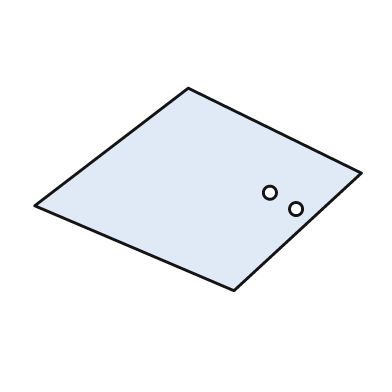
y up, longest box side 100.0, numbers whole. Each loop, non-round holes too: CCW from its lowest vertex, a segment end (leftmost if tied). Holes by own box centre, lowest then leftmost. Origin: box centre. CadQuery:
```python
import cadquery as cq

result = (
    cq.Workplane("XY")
    .moveTo(11.0, -31.0)
    .lineTo(50.0, 5.0)
    .lineTo(-3.0, 31.0)
    .lineTo(-50.0, -5.0)
    .close()
    .moveTo(30.0, -6.0)
    .circle(2.0)
    .moveTo(22.0, -1.0)
    .circle(2.0)
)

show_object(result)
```